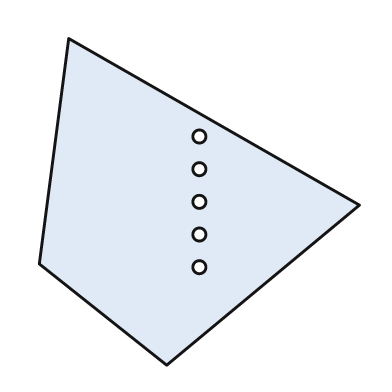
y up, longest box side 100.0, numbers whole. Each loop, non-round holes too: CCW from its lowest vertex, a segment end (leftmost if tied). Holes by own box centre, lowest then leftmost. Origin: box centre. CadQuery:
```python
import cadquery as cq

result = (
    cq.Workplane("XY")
    .moveTo(-10.0, -50.0)
    .lineTo(49.0, -1.0)
    .lineTo(-40.0, 50.0)
    .lineTo(-49.0, -19.0)
    .close()
    .moveTo(0.0, -20.0)
    .circle(2.0)
    .moveTo(0.0, -10.0)
    .circle(2.0)
    .moveTo(0.0, 0.0)
    .circle(2.0)
    .moveTo(0.0, 10.0)
    .circle(2.0)
    .moveTo(0.0, 20.0)
    .circle(2.0)
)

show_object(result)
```